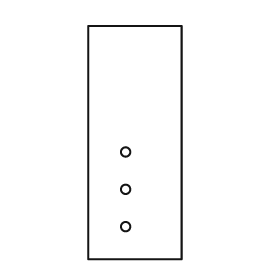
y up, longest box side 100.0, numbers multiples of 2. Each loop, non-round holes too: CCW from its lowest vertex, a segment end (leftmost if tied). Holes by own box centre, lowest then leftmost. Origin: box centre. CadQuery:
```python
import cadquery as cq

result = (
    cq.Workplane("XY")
    .moveTo(-20.0, -50.0)
    .lineTo(20.0, -50.0)
    .lineTo(20.0, 50.0)
    .lineTo(-20.0, 50.0)
    .close()
    .moveTo(-4.0, -36.0)
    .circle(2.0)
    .moveTo(-4.0, -20.0)
    .circle(2.0)
    .moveTo(-4.0, -4.0)
    .circle(2.0)
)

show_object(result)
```